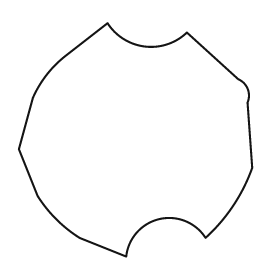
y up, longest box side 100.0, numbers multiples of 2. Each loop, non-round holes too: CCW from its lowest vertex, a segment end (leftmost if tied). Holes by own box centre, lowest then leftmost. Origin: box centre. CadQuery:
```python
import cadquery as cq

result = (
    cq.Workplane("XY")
    .moveTo(-4.0, -50.0)
    .threePointArc((10.0, -34.0), (30.0, -42.0))
    .threePointArc((42.0, -28.0), (50.0, -12.0))
    .lineTo(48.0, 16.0)
    .threePointArc((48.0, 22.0), (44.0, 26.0))
    .lineTo(22.0, 46.0)
    .threePointArc((4.0, 40.0), (-12.0, 50.0))
    .lineTo(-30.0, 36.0)
    .threePointArc((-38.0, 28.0), (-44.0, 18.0))
    .lineTo(-50.0, -4.0)
    .lineTo(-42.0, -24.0)
    .threePointArc((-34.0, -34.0), (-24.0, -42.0))
    .close()
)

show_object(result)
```